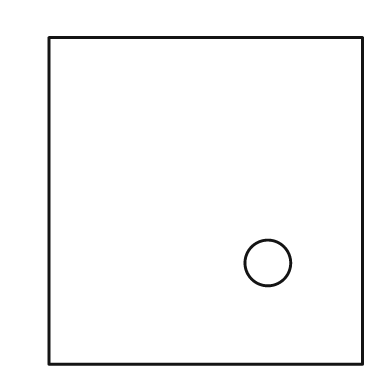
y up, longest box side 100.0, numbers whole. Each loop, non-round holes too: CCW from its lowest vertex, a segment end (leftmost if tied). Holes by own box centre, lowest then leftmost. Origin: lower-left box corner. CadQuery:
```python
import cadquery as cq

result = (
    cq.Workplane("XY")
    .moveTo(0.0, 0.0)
    .lineTo(96.0, 0.0)
    .lineTo(96.0, 100.0)
    .lineTo(0.0, 100.0)
    .close()
    .moveTo(67.0, 31.0)
    .circle(7.0)
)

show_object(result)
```